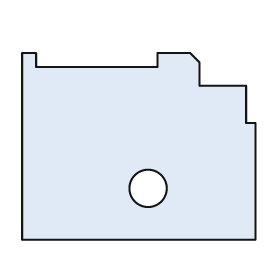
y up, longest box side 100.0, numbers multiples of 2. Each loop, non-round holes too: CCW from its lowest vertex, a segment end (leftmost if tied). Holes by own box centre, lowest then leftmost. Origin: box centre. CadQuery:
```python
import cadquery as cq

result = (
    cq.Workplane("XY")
    .moveTo(-50.0, -40.0)
    .lineTo(50.0, -40.0)
    .lineTo(50.0, 10.0)
    .lineTo(46.0, 10.0)
    .lineTo(46.0, 26.0)
    .lineTo(26.0, 26.0)
    .lineTo(26.0, 36.0)
    .lineTo(22.0, 40.0)
    .lineTo(8.0, 40.0)
    .lineTo(8.0, 34.0)
    .lineTo(-44.0, 34.0)
    .lineTo(-44.0, 40.0)
    .lineTo(-50.0, 40.0)
    .close()
    .moveTo(4.0, -18.0)
    .circle(8.0)
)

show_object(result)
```